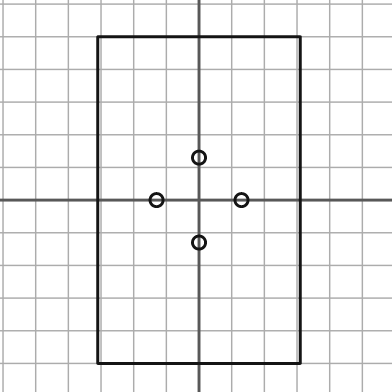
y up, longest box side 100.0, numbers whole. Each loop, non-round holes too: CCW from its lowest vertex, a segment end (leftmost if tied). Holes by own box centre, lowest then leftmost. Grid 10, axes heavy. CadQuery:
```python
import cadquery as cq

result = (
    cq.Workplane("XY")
    .moveTo(-31.0, -50.0)
    .lineTo(31.0, -50.0)
    .lineTo(31.0, 50.0)
    .lineTo(-31.0, 50.0)
    .close()
    .moveTo(0.0, -13.0)
    .circle(2.0)
    .moveTo(-13.0, 0.0)
    .circle(2.0)
    .moveTo(13.0, 0.0)
    .circle(2.0)
    .moveTo(0.0, 13.0)
    .circle(2.0)
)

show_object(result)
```